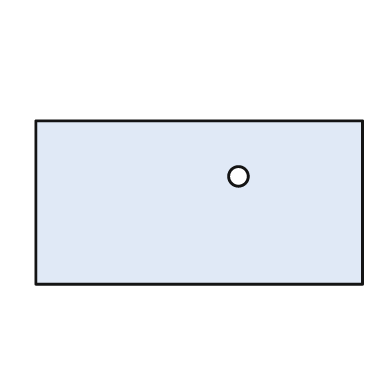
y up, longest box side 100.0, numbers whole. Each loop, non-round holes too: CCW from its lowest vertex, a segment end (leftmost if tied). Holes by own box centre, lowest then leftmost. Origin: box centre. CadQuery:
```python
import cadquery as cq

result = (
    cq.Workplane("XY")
    .moveTo(-50.0, -25.0)
    .lineTo(50.0, -25.0)
    .lineTo(50.0, 25.0)
    .lineTo(-50.0, 25.0)
    .close()
    .moveTo(12.0, 8.0)
    .circle(3.0)
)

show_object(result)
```